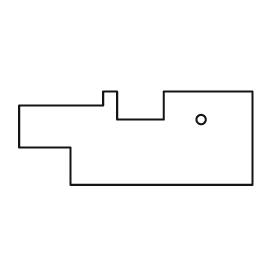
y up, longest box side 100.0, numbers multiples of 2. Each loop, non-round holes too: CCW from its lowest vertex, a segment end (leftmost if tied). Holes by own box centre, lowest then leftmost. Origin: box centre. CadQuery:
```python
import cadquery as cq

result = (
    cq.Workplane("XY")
    .moveTo(-28.0, -20.0)
    .lineTo(50.0, -20.0)
    .lineTo(50.0, 20.0)
    .lineTo(12.0, 20.0)
    .lineTo(12.0, 8.0)
    .lineTo(-8.0, 8.0)
    .lineTo(-8.0, 20.0)
    .lineTo(-14.0, 20.0)
    .lineTo(-14.0, 14.0)
    .lineTo(-50.0, 14.0)
    .lineTo(-50.0, -4.0)
    .lineTo(-28.0, -4.0)
    .close()
    .moveTo(28.0, 8.0)
    .circle(2.0)
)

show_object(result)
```